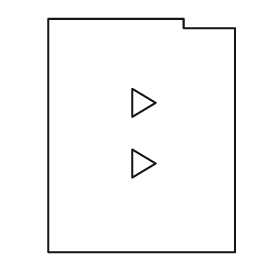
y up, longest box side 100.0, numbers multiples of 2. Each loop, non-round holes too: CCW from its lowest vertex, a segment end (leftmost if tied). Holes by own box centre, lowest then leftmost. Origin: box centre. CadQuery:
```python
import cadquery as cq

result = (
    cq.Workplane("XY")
    .moveTo(-40.0, -50.0)
    .lineTo(40.0, -50.0)
    .lineTo(40.0, 46.0)
    .lineTo(18.0, 46.0)
    .lineTo(18.0, 50.0)
    .lineTo(-40.0, 50.0)
    .close()
    .moveTo(-4.0, -18.0)
    .lineTo(6.0, -12.0)
    .lineTo(-4.0, -6.0)
    .close()
    .moveTo(-4.0, 8.0)
    .lineTo(6.0, 14.0)
    .lineTo(-4.0, 20.0)
    .close()
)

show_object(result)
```